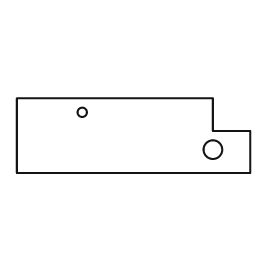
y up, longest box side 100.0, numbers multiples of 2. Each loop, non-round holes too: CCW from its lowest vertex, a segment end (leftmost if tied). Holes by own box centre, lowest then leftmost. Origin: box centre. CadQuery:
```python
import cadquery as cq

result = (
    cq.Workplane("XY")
    .moveTo(-50.0, -16.0)
    .lineTo(50.0, -16.0)
    .lineTo(50.0, 2.0)
    .lineTo(34.0, 2.0)
    .lineTo(34.0, 16.0)
    .lineTo(-50.0, 16.0)
    .close()
    .moveTo(34.0, -6.0)
    .circle(4.0)
    .moveTo(-22.0, 10.0)
    .circle(2.0)
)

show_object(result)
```